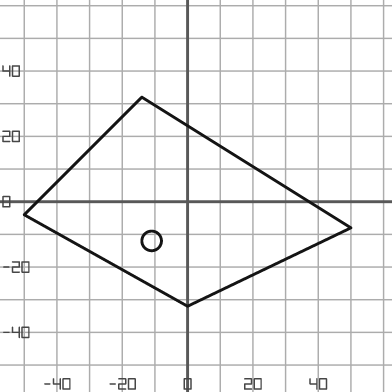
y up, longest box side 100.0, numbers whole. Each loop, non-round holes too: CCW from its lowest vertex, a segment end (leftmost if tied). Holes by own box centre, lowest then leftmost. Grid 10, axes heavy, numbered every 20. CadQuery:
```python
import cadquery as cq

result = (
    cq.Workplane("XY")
    .moveTo(0.0, -32.0)
    .lineTo(50.0, -8.0)
    .lineTo(-14.0, 32.0)
    .lineTo(-50.0, -4.0)
    .close()
    .moveTo(-11.0, -12.0)
    .circle(3.0)
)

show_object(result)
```